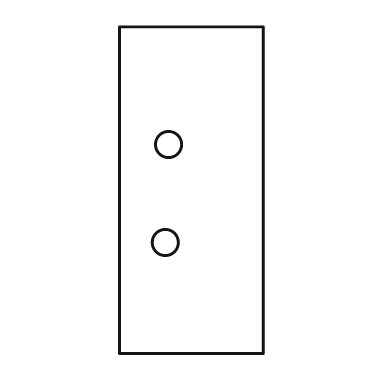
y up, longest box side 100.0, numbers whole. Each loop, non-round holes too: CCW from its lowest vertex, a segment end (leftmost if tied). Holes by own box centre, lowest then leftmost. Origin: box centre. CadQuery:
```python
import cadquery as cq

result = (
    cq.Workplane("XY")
    .moveTo(-22.0, -50.0)
    .lineTo(22.0, -50.0)
    .lineTo(22.0, 50.0)
    .lineTo(-22.0, 50.0)
    .close()
    .moveTo(-8.0, -16.0)
    .circle(4.0)
    .moveTo(-7.0, 14.0)
    .circle(4.0)
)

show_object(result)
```